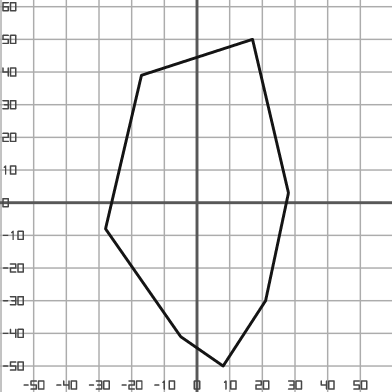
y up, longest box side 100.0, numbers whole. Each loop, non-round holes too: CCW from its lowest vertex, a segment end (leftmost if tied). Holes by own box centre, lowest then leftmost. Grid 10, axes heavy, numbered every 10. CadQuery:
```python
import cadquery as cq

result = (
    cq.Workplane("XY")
    .moveTo(8.0, -50.0)
    .lineTo(21.0, -30.0)
    .lineTo(28.0, 3.0)
    .lineTo(17.0, 50.0)
    .lineTo(-17.0, 39.0)
    .lineTo(-28.0, -8.0)
    .lineTo(-5.0, -41.0)
    .close()
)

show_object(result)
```